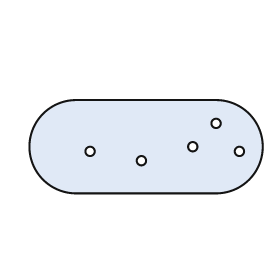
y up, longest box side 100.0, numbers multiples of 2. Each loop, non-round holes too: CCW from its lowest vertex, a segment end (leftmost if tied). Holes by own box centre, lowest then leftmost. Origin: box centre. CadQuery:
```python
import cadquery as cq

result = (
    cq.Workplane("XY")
    .moveTo(-30.0, -20.0)
    .lineTo(30.0, -20.0)
    .threePointArc((50.0, 0.0), (30.0, 20.0))
    .lineTo(-30.0, 20.0)
    .threePointArc((-50.0, 0.0), (-30.0, -20.0))
    .close()
    .moveTo(-2.0, -6.0)
    .circle(2.0)
    .moveTo(-24.0, -2.0)
    .circle(2.0)
    .moveTo(40.0, -2.0)
    .circle(2.0)
    .moveTo(20.0, 0.0)
    .circle(2.0)
    .moveTo(30.0, 10.0)
    .circle(2.0)
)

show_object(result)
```